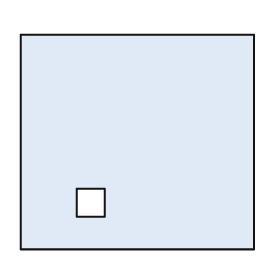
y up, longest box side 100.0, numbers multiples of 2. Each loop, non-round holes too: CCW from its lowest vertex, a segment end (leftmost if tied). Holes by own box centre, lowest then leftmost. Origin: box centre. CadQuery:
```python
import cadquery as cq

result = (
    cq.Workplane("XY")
    .moveTo(-50.0, -46.0)
    .lineTo(50.0, -46.0)
    .lineTo(50.0, 46.0)
    .lineTo(-50.0, 46.0)
    .close()
    .moveTo(-26.0, -32.0)
    .lineTo(-14.0, -32.0)
    .lineTo(-14.0, -20.0)
    .lineTo(-26.0, -20.0)
    .close()
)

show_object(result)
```